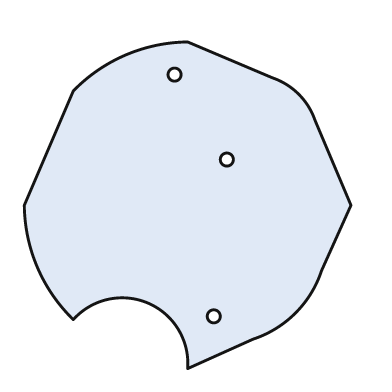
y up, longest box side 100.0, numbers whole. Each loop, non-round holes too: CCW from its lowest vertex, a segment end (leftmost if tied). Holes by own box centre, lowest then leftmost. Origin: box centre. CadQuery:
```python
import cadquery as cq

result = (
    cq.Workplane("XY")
    .moveTo(0.0, -50.0)
    .lineTo(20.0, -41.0)
    .threePointArc((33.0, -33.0), (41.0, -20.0))
    .lineTo(50.0, 0.0)
    .lineTo(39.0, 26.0)
    .threePointArc((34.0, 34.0), (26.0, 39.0))
    .lineTo(0.0, 50.0)
    .threePointArc((-19.0, 46.0), (-35.0, 35.0))
    .lineTo(-50.0, 0.0)
    .threePointArc((-46.0, -19.0), (-35.0, -35.0))
    .threePointArc((-12.0, -30.0), (0.0, -50.0))
    .close()
    .moveTo(8.0, -34.0)
    .circle(2.0)
    .moveTo(12.0, 14.0)
    .circle(2.0)
    .moveTo(-4.0, 40.0)
    .circle(2.0)
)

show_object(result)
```